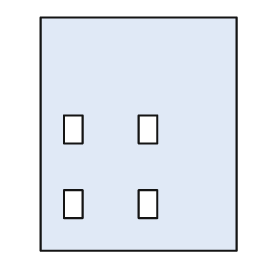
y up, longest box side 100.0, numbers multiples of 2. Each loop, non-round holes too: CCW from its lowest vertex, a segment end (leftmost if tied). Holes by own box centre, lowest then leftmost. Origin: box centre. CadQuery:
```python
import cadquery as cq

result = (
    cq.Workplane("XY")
    .moveTo(-42.0, -50.0)
    .lineTo(42.0, -50.0)
    .lineTo(42.0, 50.0)
    .lineTo(-42.0, 50.0)
    .close()
    .moveTo(-32.0, -36.0)
    .lineTo(-24.0, -36.0)
    .lineTo(-24.0, -24.0)
    .lineTo(-32.0, -24.0)
    .close()
    .moveTo(0.0, -36.0)
    .lineTo(8.0, -36.0)
    .lineTo(8.0, -24.0)
    .lineTo(0.0, -24.0)
    .close()
    .moveTo(-32.0, -4.0)
    .lineTo(-24.0, -4.0)
    .lineTo(-24.0, 8.0)
    .lineTo(-32.0, 8.0)
    .close()
    .moveTo(0.0, -4.0)
    .lineTo(8.0, -4.0)
    .lineTo(8.0, 8.0)
    .lineTo(0.0, 8.0)
    .close()
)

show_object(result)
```